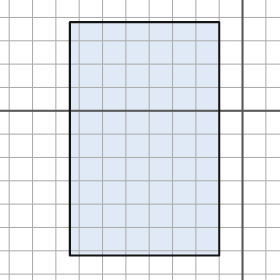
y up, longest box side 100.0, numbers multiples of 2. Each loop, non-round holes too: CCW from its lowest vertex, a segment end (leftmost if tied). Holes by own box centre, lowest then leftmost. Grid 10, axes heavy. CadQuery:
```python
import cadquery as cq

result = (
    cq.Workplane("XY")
    .moveTo(-74.0, -62.0)
    .lineTo(-10.0, -62.0)
    .lineTo(-10.0, 38.0)
    .lineTo(-74.0, 38.0)
    .close()
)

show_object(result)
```